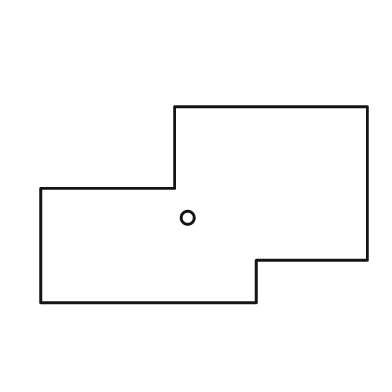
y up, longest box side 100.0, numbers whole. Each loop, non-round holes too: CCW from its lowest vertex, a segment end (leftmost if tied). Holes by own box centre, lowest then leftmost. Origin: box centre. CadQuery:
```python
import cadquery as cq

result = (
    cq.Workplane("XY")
    .moveTo(-50.0, -30.0)
    .lineTo(16.0, -30.0)
    .lineTo(16.0, -17.0)
    .lineTo(50.0, -17.0)
    .lineTo(50.0, 30.0)
    .lineTo(-9.0, 30.0)
    .lineTo(-9.0, 5.0)
    .lineTo(-50.0, 5.0)
    .close()
    .moveTo(-5.0, -4.0)
    .circle(2.0)
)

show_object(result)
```